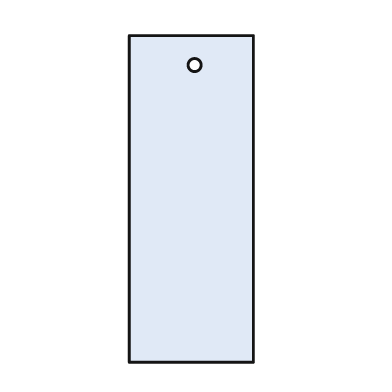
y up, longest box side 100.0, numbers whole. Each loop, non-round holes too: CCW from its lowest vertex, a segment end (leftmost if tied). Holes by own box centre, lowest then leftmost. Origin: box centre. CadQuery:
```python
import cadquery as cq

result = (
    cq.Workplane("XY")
    .moveTo(-19.0, -50.0)
    .lineTo(19.0, -50.0)
    .lineTo(19.0, 50.0)
    .lineTo(-19.0, 50.0)
    .close()
    .moveTo(1.0, 41.0)
    .circle(2.0)
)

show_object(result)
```